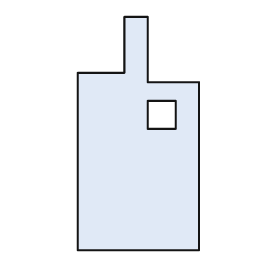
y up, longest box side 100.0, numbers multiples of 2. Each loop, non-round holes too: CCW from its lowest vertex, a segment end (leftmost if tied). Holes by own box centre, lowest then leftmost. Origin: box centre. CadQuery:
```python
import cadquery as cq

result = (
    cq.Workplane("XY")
    .moveTo(-26.0, -50.0)
    .lineTo(26.0, -50.0)
    .lineTo(26.0, 22.0)
    .lineTo(4.0, 22.0)
    .lineTo(4.0, 50.0)
    .lineTo(-6.0, 50.0)
    .lineTo(-6.0, 26.0)
    .lineTo(-26.0, 26.0)
    .close()
    .moveTo(4.0, 2.0)
    .lineTo(16.0, 2.0)
    .lineTo(16.0, 14.0)
    .lineTo(4.0, 14.0)
    .close()
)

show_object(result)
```